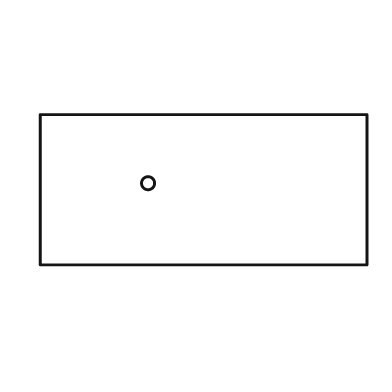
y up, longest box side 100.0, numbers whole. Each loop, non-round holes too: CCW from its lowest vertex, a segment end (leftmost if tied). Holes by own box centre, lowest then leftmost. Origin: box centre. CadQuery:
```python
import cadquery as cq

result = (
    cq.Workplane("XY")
    .moveTo(-50.0, -23.0)
    .lineTo(50.0, -23.0)
    .lineTo(50.0, 23.0)
    .lineTo(-50.0, 23.0)
    .close()
    .moveTo(-17.0, 2.0)
    .circle(2.0)
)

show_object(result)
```